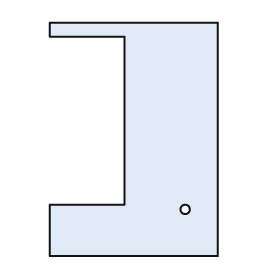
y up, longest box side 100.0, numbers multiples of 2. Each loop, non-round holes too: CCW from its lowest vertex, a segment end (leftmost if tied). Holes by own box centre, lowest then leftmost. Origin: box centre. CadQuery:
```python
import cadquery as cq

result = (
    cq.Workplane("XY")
    .moveTo(-36.0, -50.0)
    .lineTo(36.0, -50.0)
    .lineTo(36.0, 50.0)
    .lineTo(-36.0, 50.0)
    .lineTo(-36.0, 44.0)
    .lineTo(-4.0, 44.0)
    .lineTo(-4.0, -28.0)
    .lineTo(-36.0, -28.0)
    .close()
    .moveTo(22.0, -30.0)
    .circle(2.0)
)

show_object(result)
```